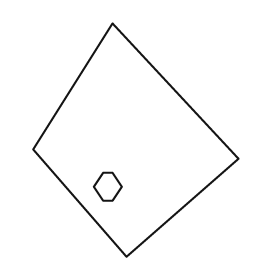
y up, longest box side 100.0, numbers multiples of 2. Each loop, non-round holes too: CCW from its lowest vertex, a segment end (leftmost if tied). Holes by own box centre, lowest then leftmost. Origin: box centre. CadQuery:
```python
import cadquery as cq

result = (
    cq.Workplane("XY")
    .moveTo(-4.0, -50.0)
    .lineTo(44.0, -8.0)
    .lineTo(-10.0, 50.0)
    .lineTo(-44.0, -4.0)
    .close()
    .moveTo(-14.0, -26.0)
    .lineTo(-10.0, -26.0)
    .lineTo(-6.0, -20.0)
    .lineTo(-10.0, -14.0)
    .lineTo(-14.0, -14.0)
    .lineTo(-18.0, -20.0)
    .close()
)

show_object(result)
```